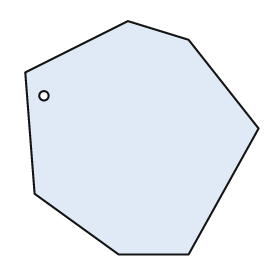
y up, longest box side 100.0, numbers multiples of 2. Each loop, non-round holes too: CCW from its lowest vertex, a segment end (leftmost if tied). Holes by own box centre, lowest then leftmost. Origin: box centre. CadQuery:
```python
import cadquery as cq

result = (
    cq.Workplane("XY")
    .moveTo(-10.0, -50.0)
    .lineTo(20.0, -50.0)
    .lineTo(50.0, 4.0)
    .lineTo(20.0, 42.0)
    .lineTo(-6.0, 50.0)
    .lineTo(-50.0, 28.0)
    .lineTo(-46.0, -24.0)
    .close()
    .moveTo(-42.0, 18.0)
    .circle(2.0)
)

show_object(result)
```